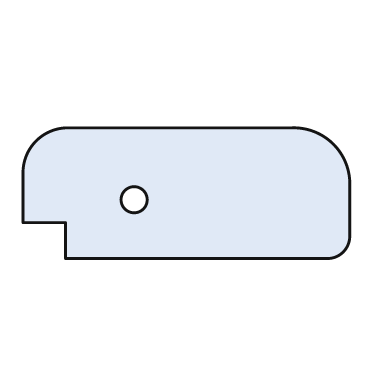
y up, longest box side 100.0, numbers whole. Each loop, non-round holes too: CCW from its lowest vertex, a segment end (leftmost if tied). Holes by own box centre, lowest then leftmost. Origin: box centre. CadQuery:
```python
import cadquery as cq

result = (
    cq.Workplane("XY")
    .moveTo(-37.0, -20.0)
    .lineTo(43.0, -20.0)
    .threePointArc((48.0, -18.0), (50.0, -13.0))
    .lineTo(50.0, 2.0)
    .threePointArc((45.0, 15.0), (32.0, 20.0))
    .lineTo(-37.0, 20.0)
    .threePointArc((-46.0, 16.0), (-50.0, 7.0))
    .lineTo(-50.0, -9.0)
    .lineTo(-37.0, -9.0)
    .close()
    .moveTo(-16.0, -2.0)
    .circle(4.0)
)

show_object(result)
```